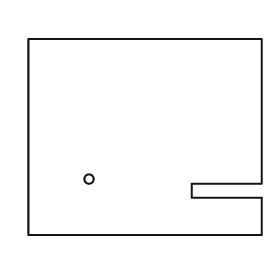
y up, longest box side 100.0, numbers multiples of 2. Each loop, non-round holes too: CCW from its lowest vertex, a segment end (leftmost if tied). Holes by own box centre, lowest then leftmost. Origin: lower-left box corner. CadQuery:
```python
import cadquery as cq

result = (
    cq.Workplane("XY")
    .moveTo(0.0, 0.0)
    .lineTo(100.0, 0.0)
    .lineTo(100.0, 16.0)
    .lineTo(70.0, 16.0)
    .lineTo(70.0, 22.0)
    .lineTo(100.0, 22.0)
    .lineTo(100.0, 84.0)
    .lineTo(0.0, 84.0)
    .close()
    .moveTo(26.0, 24.0)
    .circle(2.0)
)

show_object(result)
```